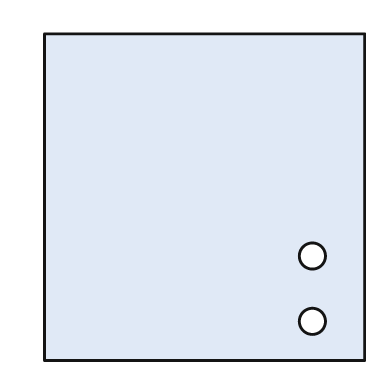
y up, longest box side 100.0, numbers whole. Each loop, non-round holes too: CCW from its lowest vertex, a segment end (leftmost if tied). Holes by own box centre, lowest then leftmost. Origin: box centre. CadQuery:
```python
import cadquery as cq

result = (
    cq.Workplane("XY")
    .moveTo(-49.0, -50.0)
    .lineTo(49.0, -50.0)
    .lineTo(49.0, 50.0)
    .lineTo(-49.0, 50.0)
    .close()
    .moveTo(33.0, -38.0)
    .circle(4.0)
    .moveTo(33.0, -18.0)
    .circle(4.0)
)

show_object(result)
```